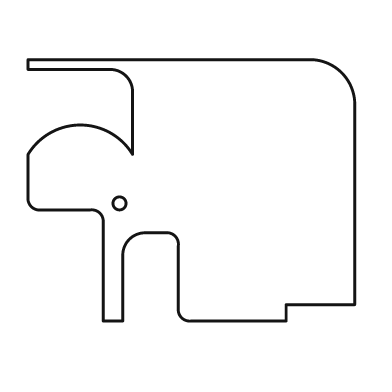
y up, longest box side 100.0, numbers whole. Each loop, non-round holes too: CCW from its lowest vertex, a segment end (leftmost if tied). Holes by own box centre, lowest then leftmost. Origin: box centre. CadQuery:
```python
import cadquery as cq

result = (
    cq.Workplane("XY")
    .moveTo(-27.0, -40.0)
    .lineTo(-21.0, -40.0)
    .lineTo(-21.0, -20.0)
    .threePointArc((-19.0, -15.0), (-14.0, -13.0))
    .lineTo(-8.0, -13.0)
    .threePointArc((-5.0, -14.0), (-4.0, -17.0))
    .lineTo(-4.0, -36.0)
    .threePointArc((-3.0, -39.0), (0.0, -40.0))
    .lineTo(29.0, -40.0)
    .lineTo(29.0, -35.0)
    .lineTo(50.0, -35.0)
    .lineTo(50.0, 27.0)
    .threePointArc((46.0, 36.0), (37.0, 40.0))
    .lineTo(-50.0, 40.0)
    .lineTo(-50.0, 37.0)
    .lineTo(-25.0, 37.0)
    .threePointArc((-20.0, 35.0), (-18.0, 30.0))
    .lineTo(-18.0, 11.0)
    .threePointArc((-34.0, 20.0), (-50.0, 11.0))
    .lineTo(-50.0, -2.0)
    .threePointArc((-49.0, -5.0), (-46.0, -6.0))
    .lineTo(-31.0, -6.0)
    .threePointArc((-28.0, -7.0), (-27.0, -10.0))
    .close()
    .moveTo(-22.0, -4.0)
    .circle(2.0)
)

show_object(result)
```